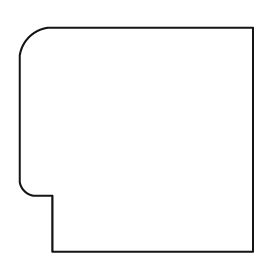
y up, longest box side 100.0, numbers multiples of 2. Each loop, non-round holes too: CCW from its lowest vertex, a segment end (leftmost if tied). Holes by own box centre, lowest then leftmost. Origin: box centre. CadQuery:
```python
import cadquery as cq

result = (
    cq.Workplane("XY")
    .moveTo(-36.0, -48.0)
    .lineTo(50.0, -48.0)
    .lineTo(50.0, 48.0)
    .lineTo(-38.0, 48.0)
    .threePointArc((-46.0, 44.0), (-50.0, 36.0))
    .lineTo(-50.0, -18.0)
    .threePointArc((-48.0, -22.0), (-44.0, -24.0))
    .lineTo(-36.0, -24.0)
    .close()
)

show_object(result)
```